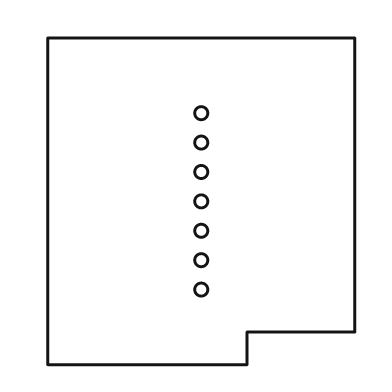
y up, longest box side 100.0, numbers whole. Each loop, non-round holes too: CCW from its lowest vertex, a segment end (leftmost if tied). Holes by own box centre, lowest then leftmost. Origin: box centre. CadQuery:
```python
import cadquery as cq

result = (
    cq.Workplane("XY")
    .moveTo(-47.0, -50.0)
    .lineTo(14.0, -50.0)
    .lineTo(14.0, -40.0)
    .lineTo(47.0, -40.0)
    .lineTo(47.0, 50.0)
    .lineTo(-47.0, 50.0)
    .close()
    .moveTo(0.0, -27.0)
    .circle(2.0)
    .moveTo(0.0, -18.0)
    .circle(2.0)
    .moveTo(0.0, -9.0)
    .circle(2.0)
    .moveTo(0.0, 0.0)
    .circle(2.0)
    .moveTo(0.0, 9.0)
    .circle(2.0)
    .moveTo(0.0, 18.0)
    .circle(2.0)
    .moveTo(0.0, 27.0)
    .circle(2.0)
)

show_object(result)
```